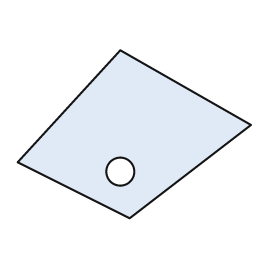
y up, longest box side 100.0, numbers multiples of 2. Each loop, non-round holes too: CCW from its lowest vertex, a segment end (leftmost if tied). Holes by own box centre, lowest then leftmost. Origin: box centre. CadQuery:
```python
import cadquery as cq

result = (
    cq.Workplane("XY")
    .moveTo(-2.0, -36.0)
    .lineTo(50.0, 4.0)
    .lineTo(-6.0, 36.0)
    .lineTo(-50.0, -12.0)
    .close()
    .moveTo(-6.0, -16.0)
    .circle(6.0)
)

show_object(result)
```